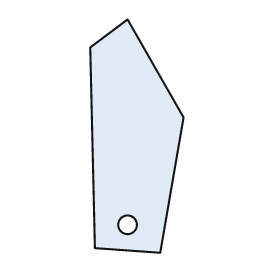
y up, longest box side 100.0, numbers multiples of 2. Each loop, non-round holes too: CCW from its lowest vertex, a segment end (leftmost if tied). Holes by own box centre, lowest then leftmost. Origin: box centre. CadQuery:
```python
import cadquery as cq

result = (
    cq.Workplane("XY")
    .moveTo(10.0, -50.0)
    .lineTo(20.0, 8.0)
    .lineTo(-4.0, 50.0)
    .lineTo(-20.0, 38.0)
    .lineTo(-18.0, -48.0)
    .close()
    .moveTo(-4.0, -38.0)
    .circle(4.0)
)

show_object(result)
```